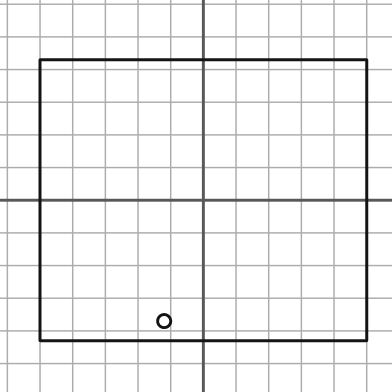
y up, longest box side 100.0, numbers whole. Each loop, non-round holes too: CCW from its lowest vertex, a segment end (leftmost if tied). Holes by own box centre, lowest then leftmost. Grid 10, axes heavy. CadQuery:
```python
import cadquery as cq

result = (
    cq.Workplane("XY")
    .moveTo(-50.0, -43.0)
    .lineTo(50.0, -43.0)
    .lineTo(50.0, 43.0)
    .lineTo(-50.0, 43.0)
    .close()
    .moveTo(-12.0, -37.0)
    .circle(2.0)
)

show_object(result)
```